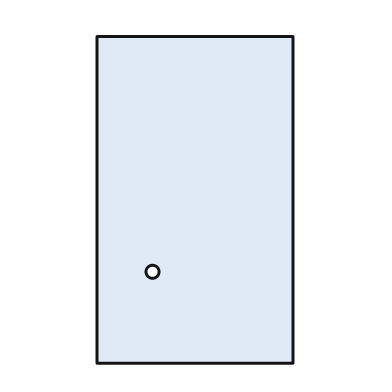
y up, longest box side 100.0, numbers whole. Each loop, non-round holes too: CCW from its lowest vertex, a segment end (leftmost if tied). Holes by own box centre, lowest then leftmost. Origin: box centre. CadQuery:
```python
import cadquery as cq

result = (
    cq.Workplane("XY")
    .moveTo(-30.0, -50.0)
    .lineTo(30.0, -50.0)
    .lineTo(30.0, 50.0)
    .lineTo(-30.0, 50.0)
    .close()
    .moveTo(-13.0, -22.0)
    .circle(2.0)
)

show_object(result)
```